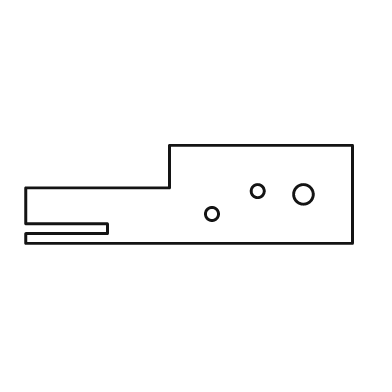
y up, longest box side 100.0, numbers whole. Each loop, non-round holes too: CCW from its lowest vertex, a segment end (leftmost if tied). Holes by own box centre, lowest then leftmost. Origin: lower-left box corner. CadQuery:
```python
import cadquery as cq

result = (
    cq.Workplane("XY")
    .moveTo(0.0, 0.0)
    .lineTo(100.0, 0.0)
    .lineTo(100.0, 30.0)
    .lineTo(44.0, 30.0)
    .lineTo(44.0, 17.0)
    .lineTo(0.0, 17.0)
    .lineTo(0.0, 6.0)
    .lineTo(25.0, 6.0)
    .lineTo(25.0, 3.0)
    .lineTo(0.0, 3.0)
    .close()
    .moveTo(57.0, 9.0)
    .circle(2.0)
    .moveTo(85.0, 15.0)
    .circle(3.0)
    .moveTo(71.0, 16.0)
    .circle(2.0)
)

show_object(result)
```